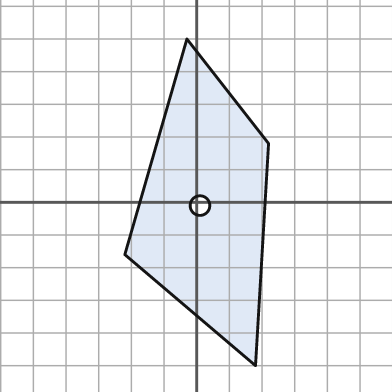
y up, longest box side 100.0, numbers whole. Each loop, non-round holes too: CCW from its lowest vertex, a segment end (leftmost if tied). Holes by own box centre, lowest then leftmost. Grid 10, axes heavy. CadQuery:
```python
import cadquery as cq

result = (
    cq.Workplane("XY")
    .moveTo(18.0, -50.0)
    .lineTo(22.0, 18.0)
    .lineTo(-3.0, 50.0)
    .lineTo(-22.0, -16.0)
    .close()
    .moveTo(1.0, -1.0)
    .circle(3.0)
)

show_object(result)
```